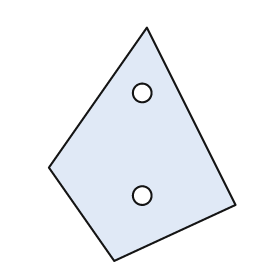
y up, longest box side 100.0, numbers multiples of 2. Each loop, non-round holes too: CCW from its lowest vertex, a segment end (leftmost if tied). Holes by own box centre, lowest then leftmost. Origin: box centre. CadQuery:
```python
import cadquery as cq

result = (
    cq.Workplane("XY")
    .moveTo(-12.0, -50.0)
    .lineTo(40.0, -26.0)
    .lineTo(2.0, 50.0)
    .lineTo(-40.0, -10.0)
    .close()
    .moveTo(0.0, -22.0)
    .circle(4.0)
    .moveTo(0.0, 22.0)
    .circle(4.0)
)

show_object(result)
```